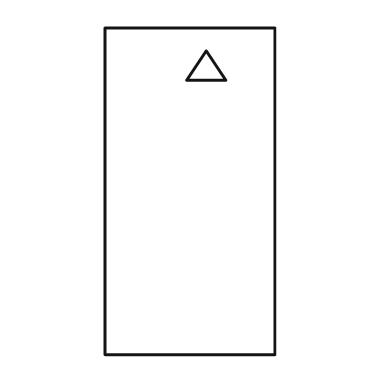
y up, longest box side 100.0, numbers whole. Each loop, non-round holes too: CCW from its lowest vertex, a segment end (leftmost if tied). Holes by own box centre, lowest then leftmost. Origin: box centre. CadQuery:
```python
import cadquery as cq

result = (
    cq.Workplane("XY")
    .moveTo(-26.0, -50.0)
    .lineTo(26.0, -50.0)
    .lineTo(26.0, 50.0)
    .lineTo(-26.0, 50.0)
    .close()
    .moveTo(-1.0, 34.0)
    .lineTo(11.0, 34.0)
    .lineTo(5.0, 43.0)
    .close()
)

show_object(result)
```